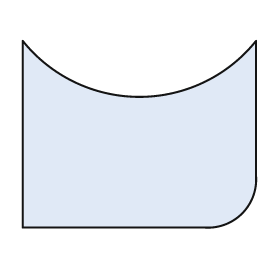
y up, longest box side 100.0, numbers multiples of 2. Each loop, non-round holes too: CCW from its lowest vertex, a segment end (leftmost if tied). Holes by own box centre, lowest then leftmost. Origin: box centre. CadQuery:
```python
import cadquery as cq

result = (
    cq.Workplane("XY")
    .moveTo(-50.0, -40.0)
    .lineTo(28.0, -40.0)
    .threePointArc((44.0, -34.0), (50.0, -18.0))
    .lineTo(50.0, 40.0)
    .threePointArc((0.0, 16.0), (-50.0, 40.0))
    .close()
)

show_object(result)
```